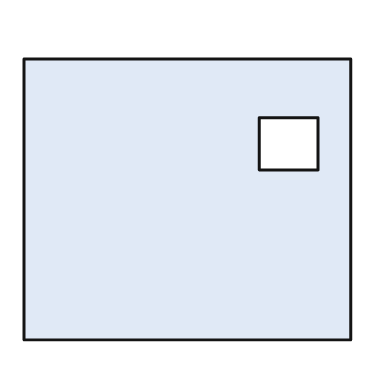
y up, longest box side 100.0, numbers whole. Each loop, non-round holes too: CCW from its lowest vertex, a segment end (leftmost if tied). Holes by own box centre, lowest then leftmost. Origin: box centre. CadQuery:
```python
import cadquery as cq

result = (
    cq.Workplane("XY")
    .moveTo(-50.0, -43.0)
    .lineTo(50.0, -43.0)
    .lineTo(50.0, 43.0)
    .lineTo(-50.0, 43.0)
    .close()
    .moveTo(22.0, 9.0)
    .lineTo(40.0, 9.0)
    .lineTo(40.0, 25.0)
    .lineTo(22.0, 25.0)
    .close()
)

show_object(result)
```